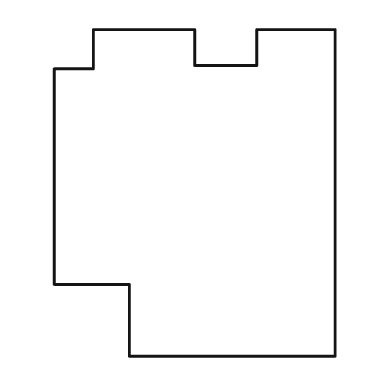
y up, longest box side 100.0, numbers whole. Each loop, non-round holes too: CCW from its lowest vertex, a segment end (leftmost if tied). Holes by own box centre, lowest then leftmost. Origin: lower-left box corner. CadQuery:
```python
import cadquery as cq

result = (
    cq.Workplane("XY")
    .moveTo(23.0, 0.0)
    .lineTo(86.0, 0.0)
    .lineTo(86.0, 100.0)
    .lineTo(62.0, 100.0)
    .lineTo(62.0, 89.0)
    .lineTo(43.0, 89.0)
    .lineTo(43.0, 100.0)
    .lineTo(12.0, 100.0)
    .lineTo(12.0, 88.0)
    .lineTo(0.0, 88.0)
    .lineTo(0.0, 22.0)
    .lineTo(23.0, 22.0)
    .close()
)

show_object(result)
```